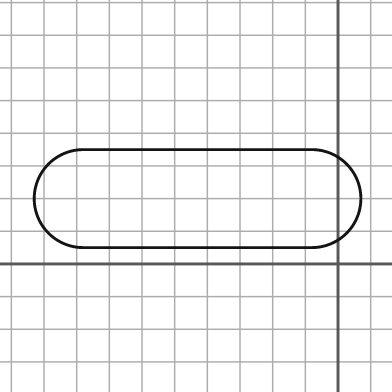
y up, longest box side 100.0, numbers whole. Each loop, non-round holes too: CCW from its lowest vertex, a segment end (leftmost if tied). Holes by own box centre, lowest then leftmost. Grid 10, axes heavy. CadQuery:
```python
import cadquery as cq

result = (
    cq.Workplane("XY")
    .moveTo(-78.0, 5.0)
    .lineTo(-8.0, 5.0)
    .threePointArc((7.0, 20.0), (-8.0, 35.0))
    .lineTo(-78.0, 35.0)
    .threePointArc((-93.0, 20.0), (-78.0, 5.0))
    .close()
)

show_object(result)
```